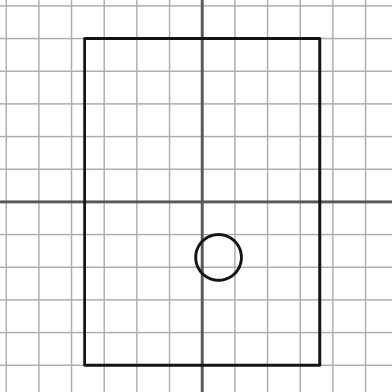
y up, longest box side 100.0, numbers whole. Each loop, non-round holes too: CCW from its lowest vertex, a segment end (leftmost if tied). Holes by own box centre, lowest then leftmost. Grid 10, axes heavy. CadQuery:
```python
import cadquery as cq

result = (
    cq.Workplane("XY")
    .moveTo(-36.0, -50.0)
    .lineTo(36.0, -50.0)
    .lineTo(36.0, 50.0)
    .lineTo(-36.0, 50.0)
    .close()
    .moveTo(5.0, -17.0)
    .circle(7.0)
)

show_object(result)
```